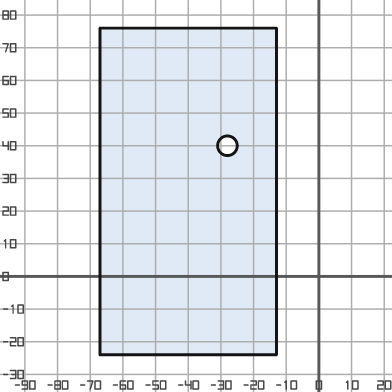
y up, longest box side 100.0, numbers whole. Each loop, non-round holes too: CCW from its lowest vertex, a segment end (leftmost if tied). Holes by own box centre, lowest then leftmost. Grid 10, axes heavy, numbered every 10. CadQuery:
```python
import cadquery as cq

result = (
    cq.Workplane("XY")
    .moveTo(-67.0, -24.0)
    .lineTo(-13.0, -24.0)
    .lineTo(-13.0, 76.0)
    .lineTo(-67.0, 76.0)
    .close()
    .moveTo(-28.0, 40.0)
    .circle(3.0)
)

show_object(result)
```